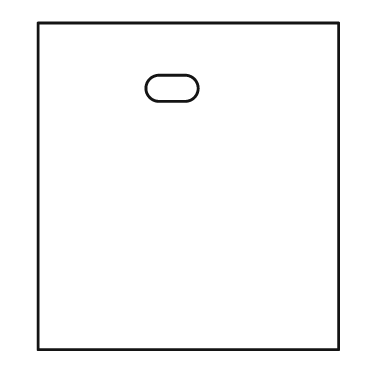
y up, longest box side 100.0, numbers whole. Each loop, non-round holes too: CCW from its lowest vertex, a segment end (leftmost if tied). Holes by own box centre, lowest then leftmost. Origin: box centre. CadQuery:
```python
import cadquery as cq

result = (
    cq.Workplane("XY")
    .moveTo(-46.0, -50.0)
    .lineTo(46.0, -50.0)
    .lineTo(46.0, 50.0)
    .lineTo(-46.0, 50.0)
    .close()
    .moveTo(-9.0, 26.0)
    .lineTo(-1.0, 26.0)
    .threePointArc((3.0, 30.0), (-1.0, 34.0))
    .lineTo(-9.0, 34.0)
    .threePointArc((-13.0, 30.0), (-9.0, 26.0))
    .close()
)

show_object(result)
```